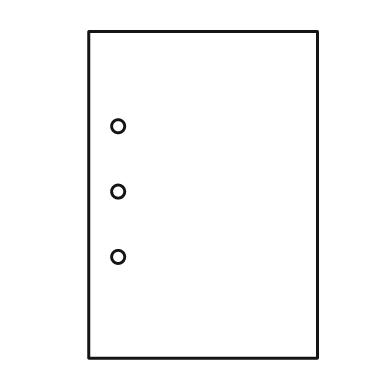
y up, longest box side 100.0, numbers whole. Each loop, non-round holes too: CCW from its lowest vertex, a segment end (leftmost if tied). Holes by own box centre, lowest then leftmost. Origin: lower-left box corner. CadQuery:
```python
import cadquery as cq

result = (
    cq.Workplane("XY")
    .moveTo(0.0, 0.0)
    .lineTo(70.0, 0.0)
    .lineTo(70.0, 100.0)
    .lineTo(0.0, 100.0)
    .close()
    .moveTo(9.0, 31.0)
    .circle(2.0)
    .moveTo(9.0, 51.0)
    .circle(2.0)
    .moveTo(9.0, 71.0)
    .circle(2.0)
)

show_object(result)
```